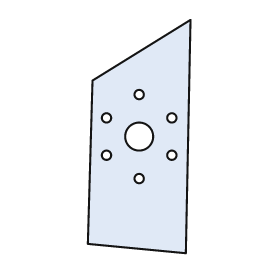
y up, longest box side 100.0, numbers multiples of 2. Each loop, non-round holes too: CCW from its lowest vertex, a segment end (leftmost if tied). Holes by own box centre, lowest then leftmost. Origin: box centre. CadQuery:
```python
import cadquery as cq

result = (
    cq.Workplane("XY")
    .moveTo(20.0, -50.0)
    .lineTo(22.0, 50.0)
    .lineTo(-20.0, 24.0)
    .lineTo(-22.0, -46.0)
    .close()
    .moveTo(0.0, -18.0)
    .circle(2.0)
    .moveTo(-14.0, -8.0)
    .circle(2.0)
    .moveTo(14.0, -8.0)
    .circle(2.0)
    .moveTo(0.0, 0.0)
    .circle(6.0)
    .moveTo(-14.0, 8.0)
    .circle(2.0)
    .moveTo(14.0, 8.0)
    .circle(2.0)
    .moveTo(0.0, 18.0)
    .circle(2.0)
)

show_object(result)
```